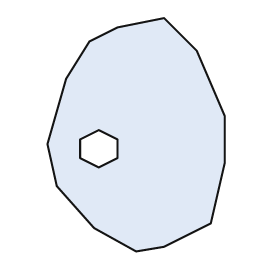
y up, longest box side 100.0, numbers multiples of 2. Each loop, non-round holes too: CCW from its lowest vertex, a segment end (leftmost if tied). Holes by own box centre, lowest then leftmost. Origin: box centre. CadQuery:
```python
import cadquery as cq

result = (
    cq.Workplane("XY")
    .moveTo(0.0, -50.0)
    .lineTo(12.0, -48.0)
    .lineTo(32.0, -38.0)
    .lineTo(38.0, -12.0)
    .lineTo(38.0, 8.0)
    .lineTo(26.0, 36.0)
    .lineTo(12.0, 50.0)
    .lineTo(-8.0, 46.0)
    .lineTo(-20.0, 40.0)
    .lineTo(-30.0, 24.0)
    .lineTo(-38.0, -4.0)
    .lineTo(-34.0, -22.0)
    .lineTo(-18.0, -40.0)
    .close()
    .moveTo(-16.0, -14.0)
    .lineTo(-8.0, -10.0)
    .lineTo(-8.0, -2.0)
    .lineTo(-16.0, 2.0)
    .lineTo(-24.0, -2.0)
    .lineTo(-24.0, -10.0)
    .close()
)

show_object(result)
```